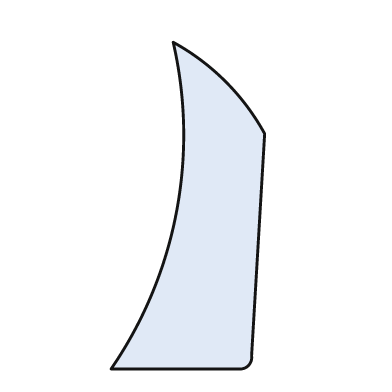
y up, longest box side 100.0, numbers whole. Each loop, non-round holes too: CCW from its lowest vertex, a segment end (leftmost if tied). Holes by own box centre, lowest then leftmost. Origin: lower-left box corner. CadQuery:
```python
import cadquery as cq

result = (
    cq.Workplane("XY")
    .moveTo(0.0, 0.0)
    .lineTo(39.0, 0.0)
    .threePointArc((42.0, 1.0), (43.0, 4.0))
    .lineTo(47.0, 72.0)
    .threePointArc((35.0, 88.0), (19.0, 100.0))
    .threePointArc((20.0, 48.0), (0.0, 0.0))
    .close()
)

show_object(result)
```